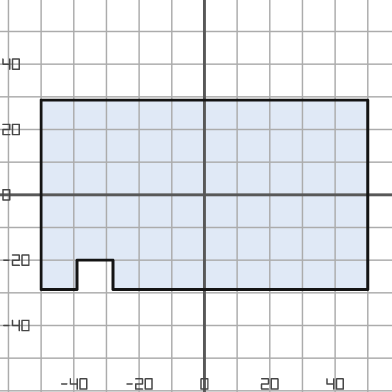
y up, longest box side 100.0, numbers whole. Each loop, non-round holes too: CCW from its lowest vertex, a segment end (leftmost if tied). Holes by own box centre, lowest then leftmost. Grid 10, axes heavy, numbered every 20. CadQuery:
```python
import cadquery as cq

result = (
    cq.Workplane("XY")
    .moveTo(-50.0, -29.0)
    .lineTo(-39.0, -29.0)
    .lineTo(-39.0, -20.0)
    .lineTo(-28.0, -20.0)
    .lineTo(-28.0, -29.0)
    .lineTo(50.0, -29.0)
    .lineTo(50.0, 29.0)
    .lineTo(-50.0, 29.0)
    .close()
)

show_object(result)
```